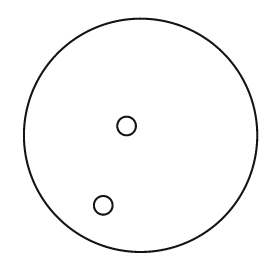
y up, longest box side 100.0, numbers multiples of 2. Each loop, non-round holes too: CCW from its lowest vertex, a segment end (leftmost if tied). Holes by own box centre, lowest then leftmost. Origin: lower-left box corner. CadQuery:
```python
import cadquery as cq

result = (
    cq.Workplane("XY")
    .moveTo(50.0, 50.0)
    .circle(50.0)
    .moveTo(34.0, 20.0)
    .circle(4.0)
    .moveTo(44.0, 54.0)
    .circle(4.0)
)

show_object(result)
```